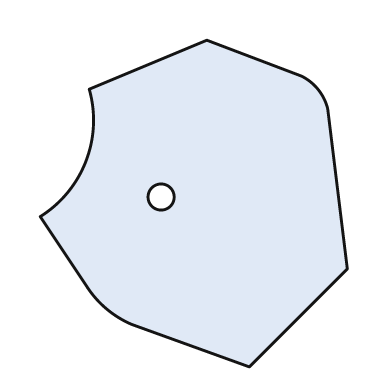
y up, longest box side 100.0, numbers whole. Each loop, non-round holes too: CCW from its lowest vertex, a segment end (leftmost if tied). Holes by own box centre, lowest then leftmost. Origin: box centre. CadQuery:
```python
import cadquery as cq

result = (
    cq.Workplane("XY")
    .moveTo(17.0, -50.0)
    .lineTo(47.0, -20.0)
    .lineTo(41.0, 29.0)
    .threePointArc((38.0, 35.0), (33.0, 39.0))
    .lineTo(4.0, 50.0)
    .lineTo(-32.0, 35.0)
    .threePointArc((-33.0, 13.0), (-47.0, -4.0))
    .lineTo(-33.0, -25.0)
    .threePointArc((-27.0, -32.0), (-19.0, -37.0))
    .close()
    .moveTo(-10.0, 2.0)
    .circle(4.0)
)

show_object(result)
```